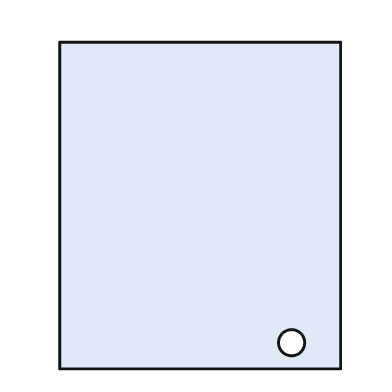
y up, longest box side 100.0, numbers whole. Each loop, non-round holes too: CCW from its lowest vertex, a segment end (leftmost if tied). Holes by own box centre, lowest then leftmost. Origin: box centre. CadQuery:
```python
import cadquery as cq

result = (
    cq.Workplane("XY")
    .moveTo(-43.0, -50.0)
    .lineTo(43.0, -50.0)
    .lineTo(43.0, 50.0)
    .lineTo(-43.0, 50.0)
    .close()
    .moveTo(28.0, -42.0)
    .circle(4.0)
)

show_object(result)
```